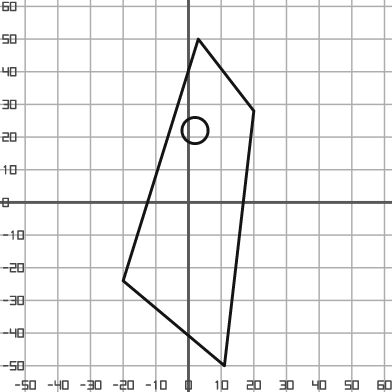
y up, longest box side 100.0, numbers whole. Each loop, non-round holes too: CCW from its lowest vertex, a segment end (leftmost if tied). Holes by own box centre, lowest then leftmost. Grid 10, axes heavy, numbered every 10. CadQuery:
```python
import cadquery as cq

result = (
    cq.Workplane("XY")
    .moveTo(11.0, -50.0)
    .lineTo(20.0, 28.0)
    .lineTo(3.0, 50.0)
    .lineTo(-20.0, -24.0)
    .close()
    .moveTo(2.0, 22.0)
    .circle(4.0)
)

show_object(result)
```